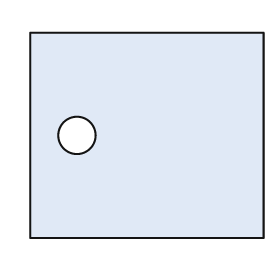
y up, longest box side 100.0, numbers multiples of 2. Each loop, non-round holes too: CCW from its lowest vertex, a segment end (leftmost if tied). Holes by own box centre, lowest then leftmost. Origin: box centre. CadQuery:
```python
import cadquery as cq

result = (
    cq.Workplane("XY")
    .moveTo(-50.0, -44.0)
    .lineTo(50.0, -44.0)
    .lineTo(50.0, 44.0)
    .lineTo(-50.0, 44.0)
    .close()
    .moveTo(-30.0, 0.0)
    .circle(8.0)
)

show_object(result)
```